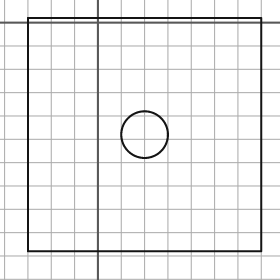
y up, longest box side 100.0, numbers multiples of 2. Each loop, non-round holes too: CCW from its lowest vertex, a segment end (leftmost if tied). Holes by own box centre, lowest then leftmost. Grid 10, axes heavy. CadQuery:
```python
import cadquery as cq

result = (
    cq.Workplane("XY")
    .moveTo(-30.0, -98.0)
    .lineTo(70.0, -98.0)
    .lineTo(70.0, 2.0)
    .lineTo(-30.0, 2.0)
    .close()
    .moveTo(20.0, -48.0)
    .circle(10.0)
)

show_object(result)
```